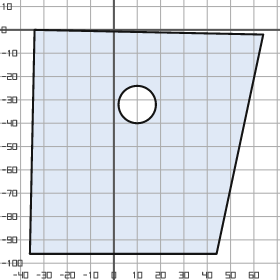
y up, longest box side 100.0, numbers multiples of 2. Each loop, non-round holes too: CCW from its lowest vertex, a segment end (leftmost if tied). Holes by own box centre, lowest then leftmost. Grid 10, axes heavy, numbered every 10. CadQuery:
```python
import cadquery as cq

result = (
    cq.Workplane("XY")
    .moveTo(-36.0, -96.0)
    .lineTo(44.0, -96.0)
    .lineTo(64.0, -2.0)
    .lineTo(-34.0, 0.0)
    .close()
    .moveTo(10.0, -32.0)
    .circle(8.0)
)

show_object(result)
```